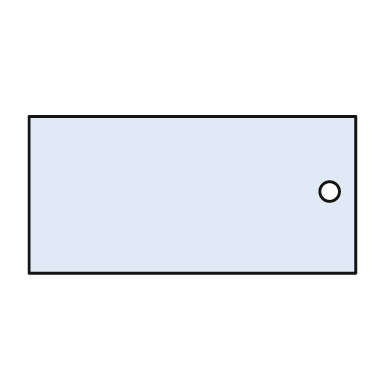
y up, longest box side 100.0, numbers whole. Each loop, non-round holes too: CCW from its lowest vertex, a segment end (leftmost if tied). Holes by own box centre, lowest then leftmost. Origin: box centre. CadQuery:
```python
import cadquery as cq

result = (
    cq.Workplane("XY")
    .moveTo(-50.0, -24.0)
    .lineTo(50.0, -24.0)
    .lineTo(50.0, 24.0)
    .lineTo(-50.0, 24.0)
    .close()
    .moveTo(42.0, 1.0)
    .circle(3.0)
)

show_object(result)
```